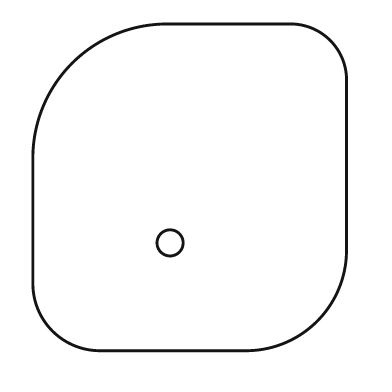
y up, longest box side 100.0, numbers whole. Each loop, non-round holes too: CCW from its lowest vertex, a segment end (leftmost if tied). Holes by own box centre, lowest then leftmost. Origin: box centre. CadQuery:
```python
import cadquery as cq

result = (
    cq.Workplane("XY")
    .moveTo(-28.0, -50.0)
    .lineTo(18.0, -50.0)
    .threePointArc((39.0, -41.0), (48.0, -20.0))
    .lineTo(48.0, 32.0)
    .threePointArc((43.0, 45.0), (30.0, 50.0))
    .lineTo(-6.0, 50.0)
    .threePointArc((-36.0, 38.0), (-48.0, 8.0))
    .lineTo(-48.0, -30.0)
    .threePointArc((-42.0, -44.0), (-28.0, -50.0))
    .close()
    .moveTo(-6.0, -17.0)
    .circle(4.0)
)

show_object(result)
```